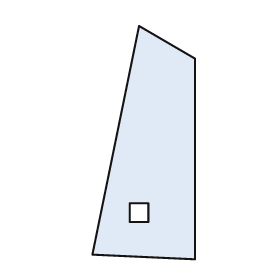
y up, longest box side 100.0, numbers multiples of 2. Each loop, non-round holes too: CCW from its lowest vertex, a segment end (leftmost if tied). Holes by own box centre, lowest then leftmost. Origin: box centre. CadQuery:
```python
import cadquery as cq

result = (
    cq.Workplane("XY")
    .moveTo(22.0, -50.0)
    .lineTo(22.0, 36.0)
    .lineTo(-2.0, 50.0)
    .lineTo(-22.0, -48.0)
    .close()
    .moveTo(-6.0, -34.0)
    .lineTo(2.0, -34.0)
    .lineTo(2.0, -26.0)
    .lineTo(-6.0, -26.0)
    .close()
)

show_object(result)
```